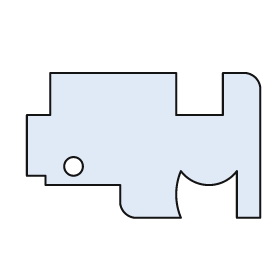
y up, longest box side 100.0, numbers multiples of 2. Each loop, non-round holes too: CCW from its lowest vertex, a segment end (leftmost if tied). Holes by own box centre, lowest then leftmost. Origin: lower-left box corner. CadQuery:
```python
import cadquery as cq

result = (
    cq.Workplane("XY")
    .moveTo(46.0, 0.0)
    .lineTo(66.0, 0.0)
    .threePointArc((64.0, 10.0), (66.0, 20.0))
    .threePointArc((78.0, 14.0), (90.0, 20.0))
    .lineTo(90.0, 0.0)
    .lineTo(100.0, 0.0)
    .lineTo(100.0, 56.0)
    .threePointArc((98.0, 60.0), (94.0, 62.0))
    .lineTo(84.0, 62.0)
    .lineTo(84.0, 44.0)
    .lineTo(64.0, 44.0)
    .lineTo(64.0, 62.0)
    .lineTo(10.0, 62.0)
    .lineTo(10.0, 44.0)
    .lineTo(0.0, 44.0)
    .lineTo(0.0, 18.0)
    .lineTo(8.0, 18.0)
    .lineTo(8.0, 14.0)
    .lineTo(40.0, 14.0)
    .lineTo(40.0, 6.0)
    .threePointArc((42.0, 2.0), (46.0, 0.0))
    .close()
    .moveTo(20.0, 22.0)
    .circle(4.0)
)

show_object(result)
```